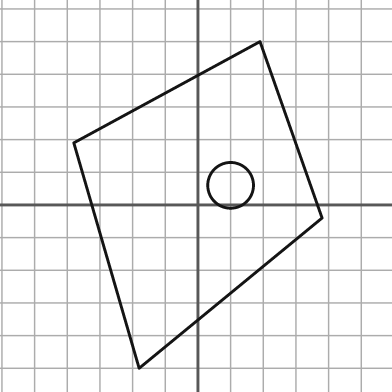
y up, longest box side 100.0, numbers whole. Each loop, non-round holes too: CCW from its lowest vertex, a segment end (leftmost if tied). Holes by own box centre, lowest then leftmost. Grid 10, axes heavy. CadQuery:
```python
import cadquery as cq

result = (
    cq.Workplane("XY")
    .moveTo(-18.0, -50.0)
    .lineTo(38.0, -4.0)
    .lineTo(19.0, 50.0)
    .lineTo(-38.0, 19.0)
    .close()
    .moveTo(10.0, 6.0)
    .circle(7.0)
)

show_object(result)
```